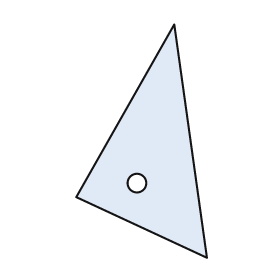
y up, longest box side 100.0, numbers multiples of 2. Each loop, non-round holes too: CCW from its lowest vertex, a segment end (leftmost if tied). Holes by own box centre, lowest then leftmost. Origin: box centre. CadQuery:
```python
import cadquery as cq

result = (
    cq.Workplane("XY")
    .moveTo(28.0, -50.0)
    .lineTo(14.0, 50.0)
    .lineTo(-28.0, -24.0)
    .close()
    .moveTo(-2.0, -18.0)
    .circle(4.0)
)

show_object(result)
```